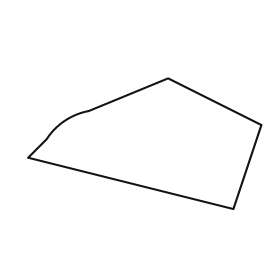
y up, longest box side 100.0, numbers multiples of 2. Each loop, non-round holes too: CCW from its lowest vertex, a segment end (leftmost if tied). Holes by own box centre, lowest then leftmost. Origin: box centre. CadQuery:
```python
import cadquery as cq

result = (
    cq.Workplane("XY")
    .moveTo(38.0, -28.0)
    .lineTo(50.0, 8.0)
    .lineTo(10.0, 28.0)
    .lineTo(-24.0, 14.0)
    .threePointArc((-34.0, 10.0), (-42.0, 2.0))
    .lineTo(-50.0, -6.0)
    .close()
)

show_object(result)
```